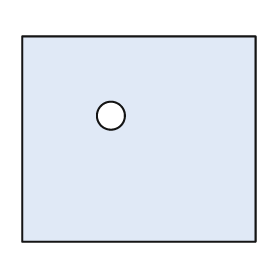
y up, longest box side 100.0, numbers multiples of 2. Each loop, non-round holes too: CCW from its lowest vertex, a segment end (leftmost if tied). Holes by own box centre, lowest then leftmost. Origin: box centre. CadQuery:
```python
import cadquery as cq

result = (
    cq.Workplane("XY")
    .moveTo(-50.0, -44.0)
    .lineTo(50.0, -44.0)
    .lineTo(50.0, 44.0)
    .lineTo(-50.0, 44.0)
    .close()
    .moveTo(-12.0, 10.0)
    .circle(6.0)
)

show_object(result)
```